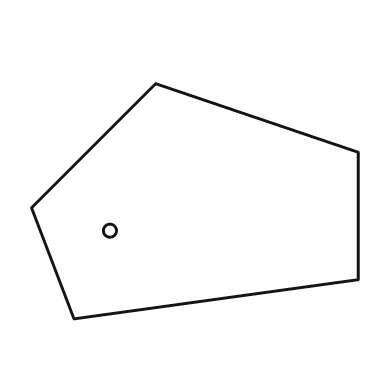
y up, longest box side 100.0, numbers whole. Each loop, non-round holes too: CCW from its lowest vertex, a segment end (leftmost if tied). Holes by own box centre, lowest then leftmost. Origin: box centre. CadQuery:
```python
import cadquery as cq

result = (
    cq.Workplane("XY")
    .moveTo(-37.0, -36.0)
    .lineTo(50.0, -24.0)
    .lineTo(50.0, 15.0)
    .lineTo(-12.0, 36.0)
    .lineTo(-50.0, -2.0)
    .close()
    .moveTo(-26.0, -9.0)
    .circle(2.0)
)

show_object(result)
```